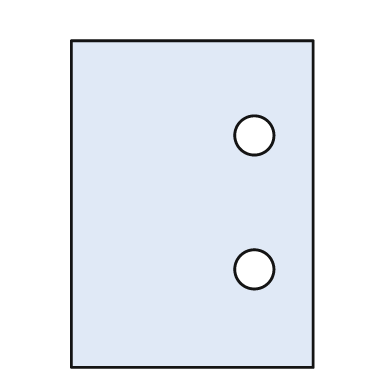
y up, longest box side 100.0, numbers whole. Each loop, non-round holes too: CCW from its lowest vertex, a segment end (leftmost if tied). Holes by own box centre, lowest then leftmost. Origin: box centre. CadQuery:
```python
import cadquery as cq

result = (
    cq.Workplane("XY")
    .moveTo(-37.0, -50.0)
    .lineTo(37.0, -50.0)
    .lineTo(37.0, 50.0)
    .lineTo(-37.0, 50.0)
    .close()
    .moveTo(19.0, -20.0)
    .circle(6.0)
    .moveTo(19.0, 21.0)
    .circle(6.0)
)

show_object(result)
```